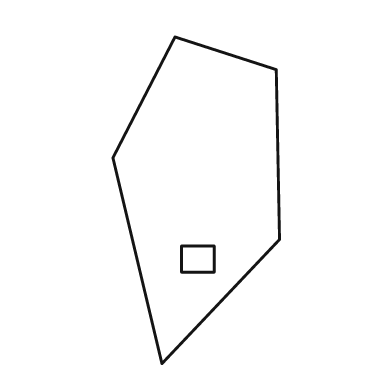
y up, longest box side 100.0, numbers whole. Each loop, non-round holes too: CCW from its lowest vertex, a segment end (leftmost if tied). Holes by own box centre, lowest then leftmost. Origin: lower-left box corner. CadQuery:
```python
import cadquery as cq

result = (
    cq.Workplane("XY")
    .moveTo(15.0, 0.0)
    .lineTo(51.0, 38.0)
    .lineTo(50.0, 90.0)
    .lineTo(19.0, 100.0)
    .lineTo(0.0, 63.0)
    .close()
    .moveTo(21.0, 28.0)
    .lineTo(31.0, 28.0)
    .lineTo(31.0, 36.0)
    .lineTo(21.0, 36.0)
    .close()
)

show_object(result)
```